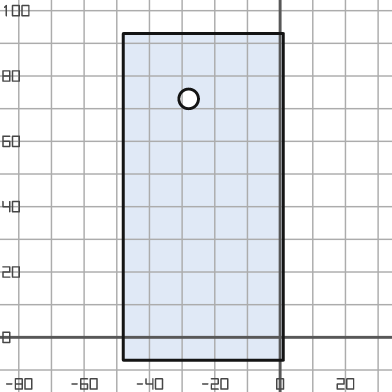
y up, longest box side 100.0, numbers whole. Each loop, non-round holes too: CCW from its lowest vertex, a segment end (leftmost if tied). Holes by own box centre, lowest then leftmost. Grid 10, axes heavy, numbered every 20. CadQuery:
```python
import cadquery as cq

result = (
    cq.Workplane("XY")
    .moveTo(-48.0, -7.0)
    .lineTo(1.0, -7.0)
    .lineTo(1.0, 93.0)
    .lineTo(-48.0, 93.0)
    .close()
    .moveTo(-28.0, 73.0)
    .circle(3.0)
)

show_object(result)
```